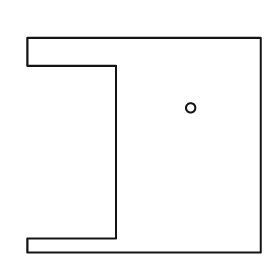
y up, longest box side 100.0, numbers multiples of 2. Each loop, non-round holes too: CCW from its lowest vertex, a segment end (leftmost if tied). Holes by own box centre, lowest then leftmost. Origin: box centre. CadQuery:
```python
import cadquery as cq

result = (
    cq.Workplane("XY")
    .moveTo(-50.0, -46.0)
    .lineTo(50.0, -46.0)
    .lineTo(50.0, 46.0)
    .lineTo(-50.0, 46.0)
    .lineTo(-50.0, 34.0)
    .lineTo(-12.0, 34.0)
    .lineTo(-12.0, -40.0)
    .lineTo(-50.0, -40.0)
    .close()
    .moveTo(20.0, 16.0)
    .circle(2.0)
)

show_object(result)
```